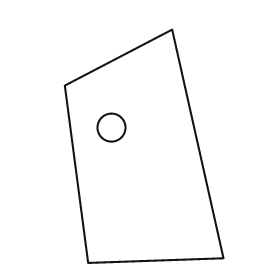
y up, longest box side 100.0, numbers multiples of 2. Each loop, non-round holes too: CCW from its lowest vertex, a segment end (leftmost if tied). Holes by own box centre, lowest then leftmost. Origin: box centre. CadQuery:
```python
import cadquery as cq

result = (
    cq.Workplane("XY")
    .moveTo(-24.0, -50.0)
    .lineTo(34.0, -48.0)
    .lineTo(12.0, 50.0)
    .lineTo(-34.0, 26.0)
    .close()
    .moveTo(-14.0, 8.0)
    .circle(6.0)
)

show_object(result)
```